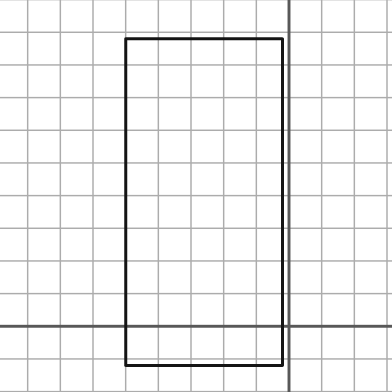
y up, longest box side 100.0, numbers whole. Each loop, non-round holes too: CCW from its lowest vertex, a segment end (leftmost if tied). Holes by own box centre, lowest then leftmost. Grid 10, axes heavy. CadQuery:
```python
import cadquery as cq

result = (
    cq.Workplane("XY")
    .moveTo(-50.0, -12.0)
    .lineTo(-2.0, -12.0)
    .lineTo(-2.0, 88.0)
    .lineTo(-50.0, 88.0)
    .close()
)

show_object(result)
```